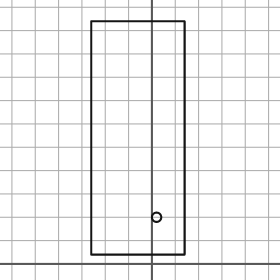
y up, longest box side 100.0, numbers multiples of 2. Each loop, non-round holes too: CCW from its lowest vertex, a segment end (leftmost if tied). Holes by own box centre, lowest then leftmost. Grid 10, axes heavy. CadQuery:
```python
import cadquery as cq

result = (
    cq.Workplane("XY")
    .moveTo(-26.0, 4.0)
    .lineTo(14.0, 4.0)
    .lineTo(14.0, 104.0)
    .lineTo(-26.0, 104.0)
    .close()
    .moveTo(2.0, 20.0)
    .circle(2.0)
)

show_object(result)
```